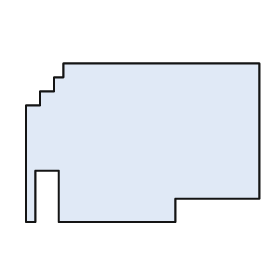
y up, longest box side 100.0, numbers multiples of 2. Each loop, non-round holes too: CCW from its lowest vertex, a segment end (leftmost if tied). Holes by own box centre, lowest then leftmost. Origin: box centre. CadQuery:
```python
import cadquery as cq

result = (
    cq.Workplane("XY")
    .moveTo(-50.0, -34.0)
    .lineTo(-46.0, -34.0)
    .lineTo(-46.0, -12.0)
    .lineTo(-36.0, -12.0)
    .lineTo(-36.0, -34.0)
    .lineTo(14.0, -34.0)
    .lineTo(14.0, -24.0)
    .lineTo(50.0, -24.0)
    .lineTo(50.0, 34.0)
    .lineTo(-34.0, 34.0)
    .lineTo(-34.0, 28.0)
    .lineTo(-38.0, 28.0)
    .lineTo(-38.0, 22.0)
    .lineTo(-44.0, 22.0)
    .lineTo(-44.0, 16.0)
    .lineTo(-50.0, 16.0)
    .close()
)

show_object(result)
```